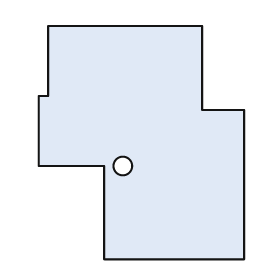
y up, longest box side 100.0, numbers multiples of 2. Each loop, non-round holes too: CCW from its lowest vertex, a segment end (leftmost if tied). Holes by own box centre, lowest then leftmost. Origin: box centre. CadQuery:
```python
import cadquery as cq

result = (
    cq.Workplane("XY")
    .moveTo(-16.0, -50.0)
    .lineTo(44.0, -50.0)
    .lineTo(44.0, 14.0)
    .lineTo(26.0, 14.0)
    .lineTo(26.0, 50.0)
    .lineTo(-40.0, 50.0)
    .lineTo(-40.0, 20.0)
    .lineTo(-44.0, 20.0)
    .lineTo(-44.0, -10.0)
    .lineTo(-16.0, -10.0)
    .close()
    .moveTo(-8.0, -10.0)
    .circle(4.0)
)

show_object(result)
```